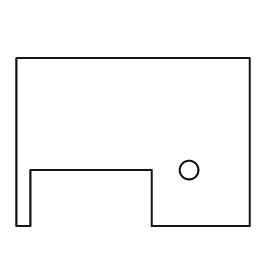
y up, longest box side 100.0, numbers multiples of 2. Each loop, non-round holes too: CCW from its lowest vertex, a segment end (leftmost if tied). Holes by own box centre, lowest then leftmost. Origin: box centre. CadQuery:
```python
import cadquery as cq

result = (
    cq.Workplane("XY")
    .moveTo(-50.0, -36.0)
    .lineTo(-44.0, -36.0)
    .lineTo(-44.0, -12.0)
    .lineTo(8.0, -12.0)
    .lineTo(8.0, -36.0)
    .lineTo(50.0, -36.0)
    .lineTo(50.0, 36.0)
    .lineTo(-50.0, 36.0)
    .close()
    .moveTo(24.0, -12.0)
    .circle(4.0)
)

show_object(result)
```